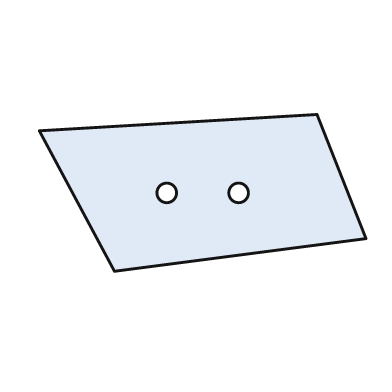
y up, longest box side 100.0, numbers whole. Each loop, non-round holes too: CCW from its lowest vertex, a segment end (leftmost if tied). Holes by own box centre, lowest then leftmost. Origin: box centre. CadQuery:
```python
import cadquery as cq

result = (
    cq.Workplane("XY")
    .moveTo(-27.0, -24.0)
    .lineTo(50.0, -14.0)
    .lineTo(35.0, 24.0)
    .lineTo(-50.0, 19.0)
    .close()
    .moveTo(-11.0, 0.0)
    .circle(3.0)
    .moveTo(11.0, 0.0)
    .circle(3.0)
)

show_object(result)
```